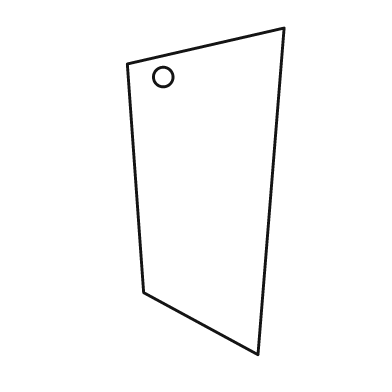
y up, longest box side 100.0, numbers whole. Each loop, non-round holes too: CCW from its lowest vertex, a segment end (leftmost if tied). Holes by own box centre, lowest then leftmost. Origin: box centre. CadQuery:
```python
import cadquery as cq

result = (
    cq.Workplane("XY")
    .moveTo(16.0, -50.0)
    .lineTo(24.0, 50.0)
    .lineTo(-24.0, 39.0)
    .lineTo(-19.0, -31.0)
    .close()
    .moveTo(-13.0, 35.0)
    .circle(3.0)
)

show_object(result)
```